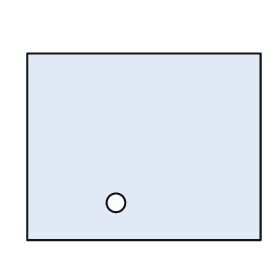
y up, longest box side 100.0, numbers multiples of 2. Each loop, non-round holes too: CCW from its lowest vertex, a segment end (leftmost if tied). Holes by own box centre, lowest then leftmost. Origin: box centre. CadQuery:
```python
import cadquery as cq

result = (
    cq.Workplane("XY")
    .moveTo(-50.0, -40.0)
    .lineTo(50.0, -40.0)
    .lineTo(50.0, 40.0)
    .lineTo(-50.0, 40.0)
    .close()
    .moveTo(-12.0, -24.0)
    .circle(4.0)
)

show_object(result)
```